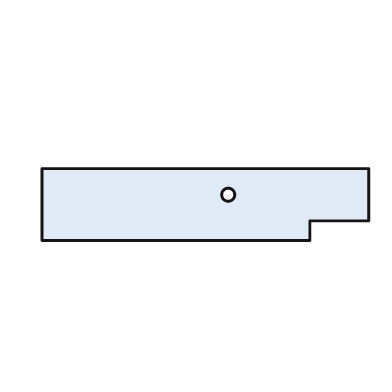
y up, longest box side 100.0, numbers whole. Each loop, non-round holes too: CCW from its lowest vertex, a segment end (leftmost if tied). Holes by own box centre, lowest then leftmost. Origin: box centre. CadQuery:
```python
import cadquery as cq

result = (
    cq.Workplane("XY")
    .moveTo(-50.0, -11.0)
    .lineTo(32.0, -11.0)
    .lineTo(32.0, -5.0)
    .lineTo(50.0, -5.0)
    .lineTo(50.0, 11.0)
    .lineTo(-50.0, 11.0)
    .close()
    .moveTo(7.0, 3.0)
    .circle(2.0)
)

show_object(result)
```